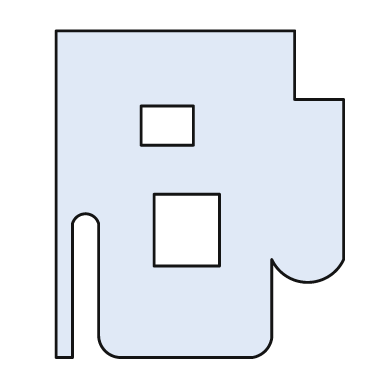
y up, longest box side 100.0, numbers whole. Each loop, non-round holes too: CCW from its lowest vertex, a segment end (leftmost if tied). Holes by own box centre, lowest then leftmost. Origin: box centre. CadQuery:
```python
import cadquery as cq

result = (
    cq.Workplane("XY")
    .moveTo(-44.0, -50.0)
    .lineTo(-39.0, -50.0)
    .lineTo(-39.0, -9.0)
    .threePointArc((-35.0, -6.0), (-31.0, -9.0))
    .lineTo(-31.0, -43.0)
    .threePointArc((-29.0, -48.0), (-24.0, -50.0))
    .lineTo(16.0, -50.0)
    .threePointArc((20.0, -48.0), (22.0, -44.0))
    .lineTo(22.0, -20.0)
    .threePointArc((33.0, -27.0), (44.0, -20.0))
    .lineTo(44.0, 29.0)
    .lineTo(29.0, 29.0)
    .lineTo(29.0, 50.0)
    .lineTo(-44.0, 50.0)
    .close()
    .moveTo(-14.0, -22.0)
    .lineTo(6.0, -22.0)
    .lineTo(6.0, 0.0)
    .lineTo(-14.0, 0.0)
    .close()
    .moveTo(-18.0, 15.0)
    .lineTo(-2.0, 15.0)
    .lineTo(-2.0, 27.0)
    .lineTo(-18.0, 27.0)
    .close()
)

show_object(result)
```